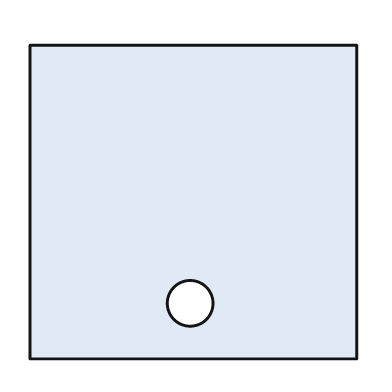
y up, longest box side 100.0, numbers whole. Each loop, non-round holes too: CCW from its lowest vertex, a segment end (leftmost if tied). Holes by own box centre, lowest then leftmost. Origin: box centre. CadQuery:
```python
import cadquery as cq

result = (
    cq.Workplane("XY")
    .moveTo(-50.0, -48.0)
    .lineTo(50.0, -48.0)
    .lineTo(50.0, 48.0)
    .lineTo(-50.0, 48.0)
    .close()
    .moveTo(-1.0, -31.0)
    .circle(7.0)
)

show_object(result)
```